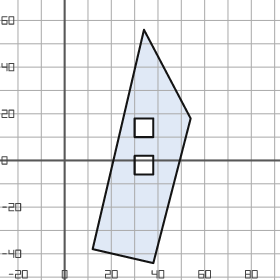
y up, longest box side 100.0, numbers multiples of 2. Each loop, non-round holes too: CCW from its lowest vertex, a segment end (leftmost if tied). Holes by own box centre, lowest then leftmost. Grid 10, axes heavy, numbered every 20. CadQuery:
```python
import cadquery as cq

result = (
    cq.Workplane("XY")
    .moveTo(38.0, -44.0)
    .lineTo(54.0, 18.0)
    .lineTo(34.0, 56.0)
    .lineTo(12.0, -38.0)
    .close()
    .moveTo(30.0, -6.0)
    .lineTo(38.0, -6.0)
    .lineTo(38.0, 2.0)
    .lineTo(30.0, 2.0)
    .close()
    .moveTo(30.0, 10.0)
    .lineTo(38.0, 10.0)
    .lineTo(38.0, 18.0)
    .lineTo(30.0, 18.0)
    .close()
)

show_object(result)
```